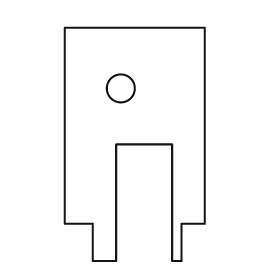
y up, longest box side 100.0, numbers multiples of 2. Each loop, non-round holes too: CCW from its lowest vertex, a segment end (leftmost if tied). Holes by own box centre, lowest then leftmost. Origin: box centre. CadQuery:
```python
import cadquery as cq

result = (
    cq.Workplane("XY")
    .moveTo(-18.0, -50.0)
    .lineTo(-8.0, -50.0)
    .lineTo(-8.0, 0.0)
    .lineTo(16.0, 0.0)
    .lineTo(16.0, -50.0)
    .lineTo(20.0, -50.0)
    .lineTo(20.0, -34.0)
    .lineTo(30.0, -34.0)
    .lineTo(30.0, 50.0)
    .lineTo(-30.0, 50.0)
    .lineTo(-30.0, -34.0)
    .lineTo(-18.0, -34.0)
    .close()
    .moveTo(-6.0, 24.0)
    .circle(6.0)
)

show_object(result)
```